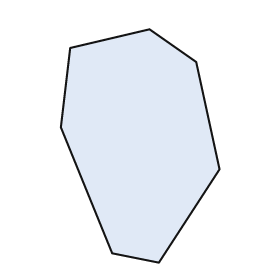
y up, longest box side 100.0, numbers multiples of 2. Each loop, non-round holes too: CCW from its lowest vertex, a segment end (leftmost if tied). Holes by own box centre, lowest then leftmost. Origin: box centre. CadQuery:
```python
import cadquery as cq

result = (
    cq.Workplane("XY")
    .moveTo(8.0, -50.0)
    .lineTo(34.0, -10.0)
    .lineTo(24.0, 36.0)
    .lineTo(4.0, 50.0)
    .lineTo(-30.0, 42.0)
    .lineTo(-34.0, 8.0)
    .lineTo(-12.0, -46.0)
    .close()
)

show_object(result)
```